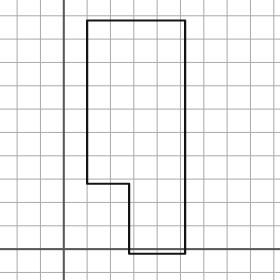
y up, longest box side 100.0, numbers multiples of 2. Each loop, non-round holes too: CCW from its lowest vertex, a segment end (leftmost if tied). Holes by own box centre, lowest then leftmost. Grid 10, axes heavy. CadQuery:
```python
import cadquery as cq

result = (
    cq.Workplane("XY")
    .moveTo(28.0, -2.0)
    .lineTo(52.0, -2.0)
    .lineTo(52.0, 98.0)
    .lineTo(10.0, 98.0)
    .lineTo(10.0, 28.0)
    .lineTo(28.0, 28.0)
    .close()
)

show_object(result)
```